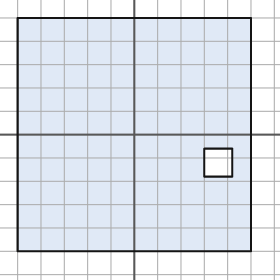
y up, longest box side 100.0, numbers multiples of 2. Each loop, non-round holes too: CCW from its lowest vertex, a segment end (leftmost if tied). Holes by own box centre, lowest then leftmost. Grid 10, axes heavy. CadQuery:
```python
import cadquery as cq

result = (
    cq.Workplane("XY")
    .moveTo(-50.0, -50.0)
    .lineTo(50.0, -50.0)
    .lineTo(50.0, 50.0)
    .lineTo(-50.0, 50.0)
    .close()
    .moveTo(30.0, -18.0)
    .lineTo(42.0, -18.0)
    .lineTo(42.0, -6.0)
    .lineTo(30.0, -6.0)
    .close()
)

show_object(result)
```